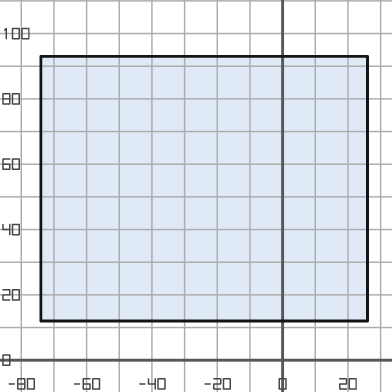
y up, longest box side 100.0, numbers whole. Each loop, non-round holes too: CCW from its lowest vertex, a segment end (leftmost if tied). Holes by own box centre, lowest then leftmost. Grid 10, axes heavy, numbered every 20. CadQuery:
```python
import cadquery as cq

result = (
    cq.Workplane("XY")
    .moveTo(-74.0, 12.0)
    .lineTo(26.0, 12.0)
    .lineTo(26.0, 93.0)
    .lineTo(-74.0, 93.0)
    .close()
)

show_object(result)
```